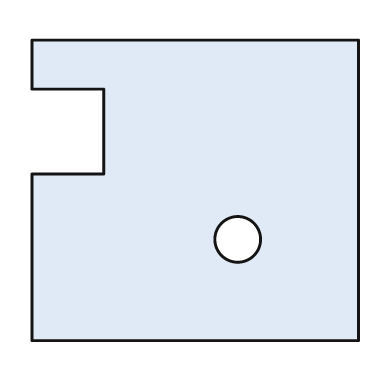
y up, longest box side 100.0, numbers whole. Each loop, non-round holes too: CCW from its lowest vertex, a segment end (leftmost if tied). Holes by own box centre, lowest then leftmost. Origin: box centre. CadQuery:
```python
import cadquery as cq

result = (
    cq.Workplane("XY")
    .moveTo(-50.0, -46.0)
    .lineTo(50.0, -46.0)
    .lineTo(50.0, 46.0)
    .lineTo(-50.0, 46.0)
    .lineTo(-50.0, 31.0)
    .lineTo(-28.0, 31.0)
    .lineTo(-28.0, 5.0)
    .lineTo(-50.0, 5.0)
    .close()
    .moveTo(13.0, -15.0)
    .circle(7.0)
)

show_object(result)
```